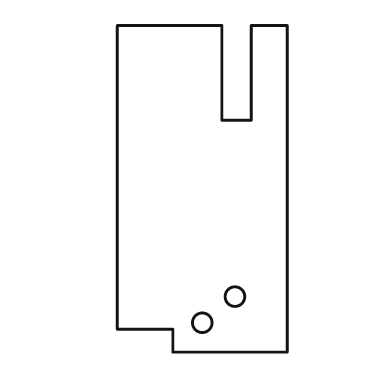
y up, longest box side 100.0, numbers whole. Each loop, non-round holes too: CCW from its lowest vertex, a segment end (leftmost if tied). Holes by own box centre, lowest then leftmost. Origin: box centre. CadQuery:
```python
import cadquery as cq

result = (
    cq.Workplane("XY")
    .moveTo(-9.0, -50.0)
    .lineTo(26.0, -50.0)
    .lineTo(26.0, 50.0)
    .lineTo(15.0, 50.0)
    .lineTo(15.0, 21.0)
    .lineTo(6.0, 21.0)
    .lineTo(6.0, 50.0)
    .lineTo(-26.0, 50.0)
    .lineTo(-26.0, -43.0)
    .lineTo(-9.0, -43.0)
    .close()
    .moveTo(0.0, -41.0)
    .circle(3.0)
    .moveTo(10.0, -33.0)
    .circle(3.0)
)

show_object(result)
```